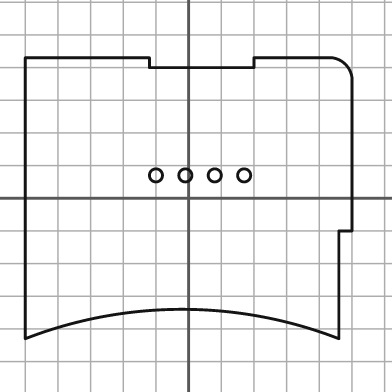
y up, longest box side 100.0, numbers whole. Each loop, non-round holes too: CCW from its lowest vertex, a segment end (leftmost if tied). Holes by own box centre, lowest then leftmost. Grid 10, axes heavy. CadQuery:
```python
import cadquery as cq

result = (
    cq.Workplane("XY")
    .moveTo(-50.0, -43.0)
    .threePointArc((-2.0, -34.0), (46.0, -43.0))
    .lineTo(46.0, -10.0)
    .lineTo(50.0, -10.0)
    .lineTo(50.0, 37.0)
    .threePointArc((48.0, 41.0), (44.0, 43.0))
    .lineTo(20.0, 43.0)
    .lineTo(20.0, 40.0)
    .lineTo(-12.0, 40.0)
    .lineTo(-12.0, 43.0)
    .lineTo(-50.0, 43.0)
    .close()
    .moveTo(-10.0, 7.0)
    .circle(2.0)
    .moveTo(-1.0, 7.0)
    .circle(2.0)
    .moveTo(8.0, 7.0)
    .circle(2.0)
    .moveTo(17.0, 7.0)
    .circle(2.0)
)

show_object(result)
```